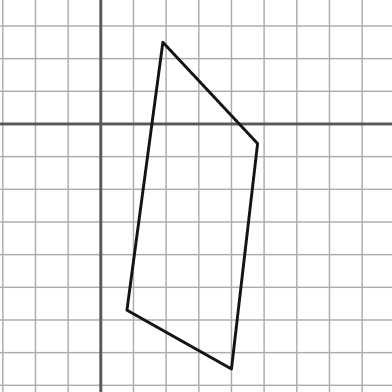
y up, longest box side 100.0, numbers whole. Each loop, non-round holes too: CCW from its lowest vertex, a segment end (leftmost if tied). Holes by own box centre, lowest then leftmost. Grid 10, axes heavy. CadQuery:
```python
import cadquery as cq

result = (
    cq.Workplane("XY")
    .moveTo(40.0, -75.0)
    .lineTo(48.0, -6.0)
    .lineTo(19.0, 25.0)
    .lineTo(8.0, -57.0)
    .close()
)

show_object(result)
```